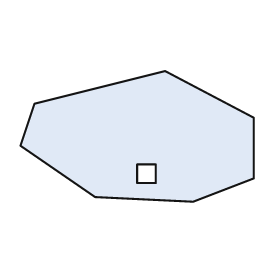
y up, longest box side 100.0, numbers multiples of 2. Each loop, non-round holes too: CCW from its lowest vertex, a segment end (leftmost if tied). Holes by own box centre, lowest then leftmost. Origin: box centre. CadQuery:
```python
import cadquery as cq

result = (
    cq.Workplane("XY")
    .moveTo(24.0, -28.0)
    .lineTo(50.0, -18.0)
    .lineTo(50.0, 8.0)
    .lineTo(12.0, 28.0)
    .lineTo(-44.0, 14.0)
    .lineTo(-50.0, -4.0)
    .lineTo(-18.0, -26.0)
    .close()
    .moveTo(0.0, -20.0)
    .lineTo(8.0, -20.0)
    .lineTo(8.0, -12.0)
    .lineTo(0.0, -12.0)
    .close()
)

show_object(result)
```